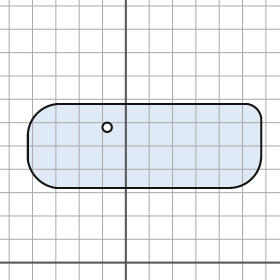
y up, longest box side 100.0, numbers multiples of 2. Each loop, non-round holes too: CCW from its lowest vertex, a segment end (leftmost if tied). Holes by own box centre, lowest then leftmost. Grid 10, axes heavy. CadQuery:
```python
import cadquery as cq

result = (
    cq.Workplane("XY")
    .moveTo(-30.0, 32.0)
    .lineTo(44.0, 32.0)
    .threePointArc((54.0, 36.0), (58.0, 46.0))
    .lineTo(58.0, 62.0)
    .threePointArc((56.0, 66.0), (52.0, 68.0))
    .lineTo(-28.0, 68.0)
    .threePointArc((-38.0, 64.0), (-42.0, 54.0))
    .lineTo(-42.0, 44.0)
    .threePointArc((-38.0, 36.0), (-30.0, 32.0))
    .close()
    .moveTo(-8.0, 58.0)
    .circle(2.0)
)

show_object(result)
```